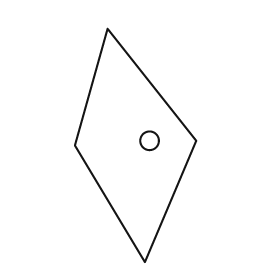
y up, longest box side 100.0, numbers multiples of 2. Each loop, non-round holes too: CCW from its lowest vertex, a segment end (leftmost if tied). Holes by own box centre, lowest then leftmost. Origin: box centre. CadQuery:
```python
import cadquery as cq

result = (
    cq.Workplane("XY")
    .moveTo(4.0, -50.0)
    .lineTo(26.0, 2.0)
    .lineTo(-12.0, 50.0)
    .lineTo(-26.0, 0.0)
    .close()
    .moveTo(6.0, 2.0)
    .circle(4.0)
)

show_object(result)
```